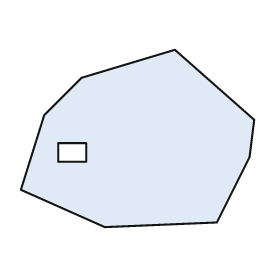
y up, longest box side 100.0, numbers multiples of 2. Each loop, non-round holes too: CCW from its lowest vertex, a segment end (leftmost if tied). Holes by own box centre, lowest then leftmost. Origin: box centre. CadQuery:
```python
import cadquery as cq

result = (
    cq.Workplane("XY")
    .moveTo(-14.0, -38.0)
    .lineTo(34.0, -36.0)
    .lineTo(48.0, -8.0)
    .lineTo(50.0, 8.0)
    .lineTo(16.0, 38.0)
    .lineTo(-24.0, 26.0)
    .lineTo(-40.0, 10.0)
    .lineTo(-50.0, -22.0)
    .close()
    .moveTo(-34.0, -10.0)
    .lineTo(-22.0, -10.0)
    .lineTo(-22.0, -2.0)
    .lineTo(-34.0, -2.0)
    .close()
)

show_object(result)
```